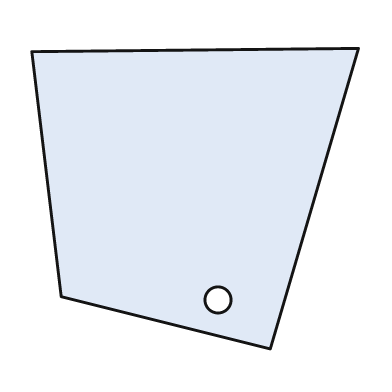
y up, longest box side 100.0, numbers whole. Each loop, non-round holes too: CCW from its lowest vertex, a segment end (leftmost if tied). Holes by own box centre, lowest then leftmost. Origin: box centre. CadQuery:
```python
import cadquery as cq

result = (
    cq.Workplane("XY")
    .moveTo(23.0, -46.0)
    .lineTo(50.0, 46.0)
    .lineTo(-50.0, 45.0)
    .lineTo(-41.0, -30.0)
    .close()
    .moveTo(7.0, -31.0)
    .circle(4.0)
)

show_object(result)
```